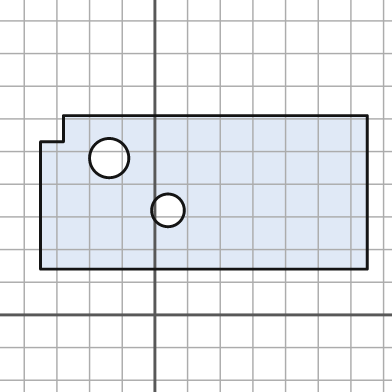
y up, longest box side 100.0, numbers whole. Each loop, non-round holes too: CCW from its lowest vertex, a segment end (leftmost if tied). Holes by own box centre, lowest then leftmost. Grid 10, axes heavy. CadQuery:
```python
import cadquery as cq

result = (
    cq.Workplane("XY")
    .moveTo(-35.0, 14.0)
    .lineTo(65.0, 14.0)
    .lineTo(65.0, 61.0)
    .lineTo(-28.0, 61.0)
    .lineTo(-28.0, 53.0)
    .lineTo(-35.0, 53.0)
    .close()
    .moveTo(4.0, 32.0)
    .circle(5.0)
    .moveTo(-14.0, 48.0)
    .circle(6.0)
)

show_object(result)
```